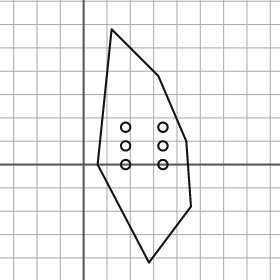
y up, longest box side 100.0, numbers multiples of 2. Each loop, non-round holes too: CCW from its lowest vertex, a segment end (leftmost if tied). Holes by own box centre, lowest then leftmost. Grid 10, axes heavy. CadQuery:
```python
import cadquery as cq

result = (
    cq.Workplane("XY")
    .moveTo(28.0, -42.0)
    .lineTo(46.0, -18.0)
    .lineTo(44.0, 10.0)
    .lineTo(32.0, 38.0)
    .lineTo(12.0, 58.0)
    .lineTo(6.0, 0.0)
    .close()
    .moveTo(18.0, 0.0)
    .circle(2.0)
    .moveTo(34.0, 0.0)
    .circle(2.0)
    .moveTo(18.0, 8.0)
    .circle(2.0)
    .moveTo(34.0, 8.0)
    .circle(2.0)
    .moveTo(18.0, 16.0)
    .circle(2.0)
    .moveTo(34.0, 16.0)
    .circle(2.0)
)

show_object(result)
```